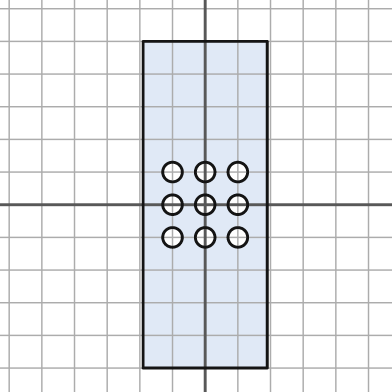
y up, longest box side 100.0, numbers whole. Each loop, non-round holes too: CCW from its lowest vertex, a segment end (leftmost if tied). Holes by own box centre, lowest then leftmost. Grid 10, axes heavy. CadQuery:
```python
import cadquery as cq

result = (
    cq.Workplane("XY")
    .moveTo(-19.0, -50.0)
    .lineTo(19.0, -50.0)
    .lineTo(19.0, 50.0)
    .lineTo(-19.0, 50.0)
    .close()
    .moveTo(-10.0, -10.0)
    .circle(3.0)
    .moveTo(0.0, -10.0)
    .circle(3.0)
    .moveTo(10.0, -10.0)
    .circle(3.0)
    .moveTo(-10.0, 0.0)
    .circle(3.0)
    .moveTo(0.0, 0.0)
    .circle(3.0)
    .moveTo(10.0, 0.0)
    .circle(3.0)
    .moveTo(-10.0, 10.0)
    .circle(3.0)
    .moveTo(0.0, 10.0)
    .circle(3.0)
    .moveTo(10.0, 10.0)
    .circle(3.0)
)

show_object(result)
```